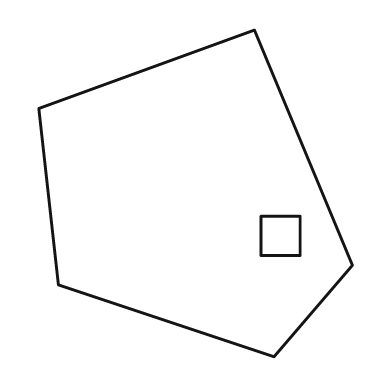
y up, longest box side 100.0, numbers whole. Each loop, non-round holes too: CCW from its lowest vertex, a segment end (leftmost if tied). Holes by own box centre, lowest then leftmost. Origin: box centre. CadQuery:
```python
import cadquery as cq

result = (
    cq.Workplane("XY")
    .moveTo(24.0, -50.0)
    .lineTo(48.0, -22.0)
    .lineTo(18.0, 50.0)
    .lineTo(-48.0, 26.0)
    .lineTo(-42.0, -28.0)
    .close()
    .moveTo(20.0, -19.0)
    .lineTo(32.0, -19.0)
    .lineTo(32.0, -7.0)
    .lineTo(20.0, -7.0)
    .close()
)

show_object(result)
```